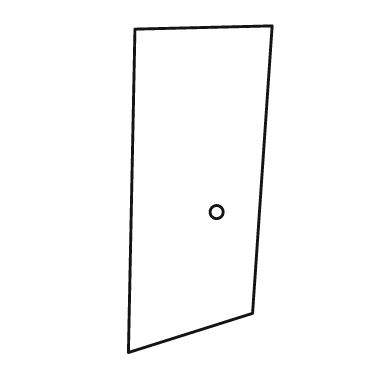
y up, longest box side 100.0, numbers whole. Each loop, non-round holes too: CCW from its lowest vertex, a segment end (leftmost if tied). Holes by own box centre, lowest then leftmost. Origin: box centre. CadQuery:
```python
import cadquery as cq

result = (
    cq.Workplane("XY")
    .moveTo(-22.0, -50.0)
    .lineTo(16.0, -38.0)
    .lineTo(22.0, 50.0)
    .lineTo(-20.0, 49.0)
    .close()
    .moveTo(5.0, -7.0)
    .circle(2.0)
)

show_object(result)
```